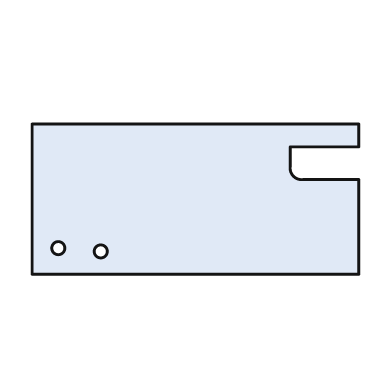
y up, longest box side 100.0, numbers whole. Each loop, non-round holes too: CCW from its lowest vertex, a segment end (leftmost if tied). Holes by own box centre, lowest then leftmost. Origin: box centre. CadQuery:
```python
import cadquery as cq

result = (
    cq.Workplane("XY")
    .moveTo(-50.0, -23.0)
    .lineTo(50.0, -23.0)
    .lineTo(50.0, 6.0)
    .lineTo(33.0, 6.0)
    .threePointArc((30.0, 7.0), (29.0, 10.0))
    .lineTo(29.0, 16.0)
    .lineTo(50.0, 16.0)
    .lineTo(50.0, 23.0)
    .lineTo(-50.0, 23.0)
    .close()
    .moveTo(-29.0, -16.0)
    .circle(2.0)
    .moveTo(-42.0, -15.0)
    .circle(2.0)
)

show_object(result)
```